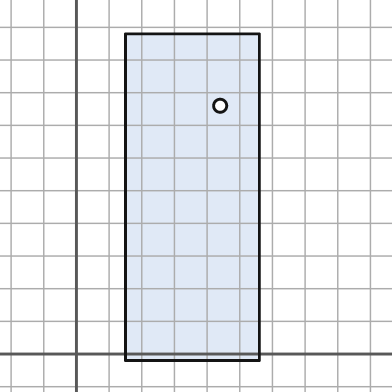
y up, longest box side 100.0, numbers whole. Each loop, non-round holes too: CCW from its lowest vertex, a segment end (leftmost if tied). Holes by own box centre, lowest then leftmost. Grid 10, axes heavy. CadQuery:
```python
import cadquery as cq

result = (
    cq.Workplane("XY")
    .moveTo(15.0, -2.0)
    .lineTo(56.0, -2.0)
    .lineTo(56.0, 98.0)
    .lineTo(15.0, 98.0)
    .close()
    .moveTo(44.0, 76.0)
    .circle(2.0)
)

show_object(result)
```